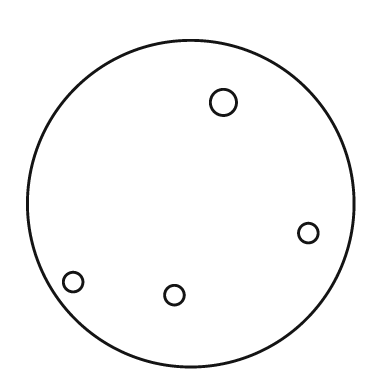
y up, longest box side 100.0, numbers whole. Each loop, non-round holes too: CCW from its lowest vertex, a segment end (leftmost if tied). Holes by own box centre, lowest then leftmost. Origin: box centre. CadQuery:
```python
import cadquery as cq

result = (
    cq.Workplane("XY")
    .moveTo(0.0, 0.0)
    .circle(50.0)
    .moveTo(-5.0, -28.0)
    .circle(3.0)
    .moveTo(-36.0, -24.0)
    .circle(3.0)
    .moveTo(36.0, -9.0)
    .circle(3.0)
    .moveTo(10.0, 31.0)
    .circle(4.0)
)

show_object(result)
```